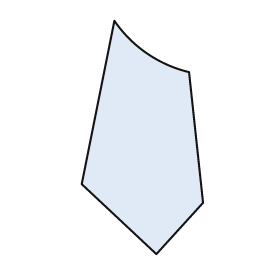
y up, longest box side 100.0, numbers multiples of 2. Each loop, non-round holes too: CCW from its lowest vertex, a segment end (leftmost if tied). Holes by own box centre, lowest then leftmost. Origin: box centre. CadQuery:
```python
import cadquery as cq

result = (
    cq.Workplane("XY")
    .moveTo(6.0, -50.0)
    .lineTo(26.0, -28.0)
    .lineTo(20.0, 28.0)
    .threePointArc((2.0, 36.0), (-12.0, 50.0))
    .lineTo(-26.0, -20.0)
    .close()
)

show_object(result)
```